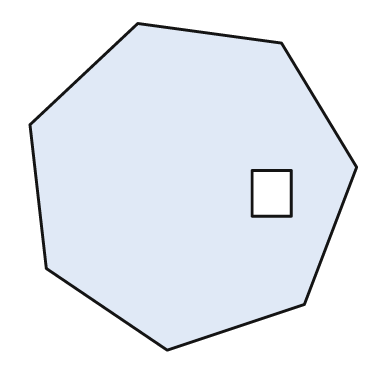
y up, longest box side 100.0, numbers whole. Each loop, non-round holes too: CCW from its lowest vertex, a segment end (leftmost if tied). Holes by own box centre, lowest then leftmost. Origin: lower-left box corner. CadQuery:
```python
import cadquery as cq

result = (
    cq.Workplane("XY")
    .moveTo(42.0, 0.0)
    .lineTo(84.0, 14.0)
    .lineTo(100.0, 56.0)
    .lineTo(77.0, 94.0)
    .lineTo(33.0, 100.0)
    .lineTo(0.0, 69.0)
    .lineTo(5.0, 25.0)
    .close()
    .moveTo(68.0, 41.0)
    .lineTo(80.0, 41.0)
    .lineTo(80.0, 55.0)
    .lineTo(68.0, 55.0)
    .close()
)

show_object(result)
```